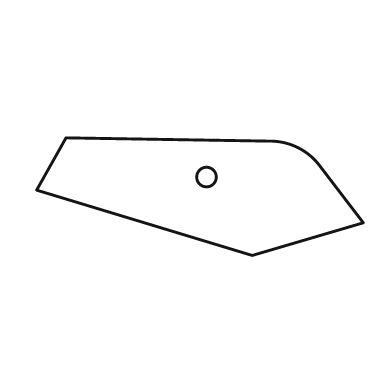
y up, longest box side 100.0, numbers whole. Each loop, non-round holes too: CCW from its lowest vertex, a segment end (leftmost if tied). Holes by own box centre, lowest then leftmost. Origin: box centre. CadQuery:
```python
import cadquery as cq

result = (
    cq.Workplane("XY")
    .moveTo(16.0, -18.0)
    .lineTo(50.0, -8.0)
    .lineTo(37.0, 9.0)
    .threePointArc((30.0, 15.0), (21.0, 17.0))
    .lineTo(-41.0, 18.0)
    .lineTo(-50.0, 2.0)
    .close()
    .moveTo(2.0, 6.0)
    .circle(3.0)
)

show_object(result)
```